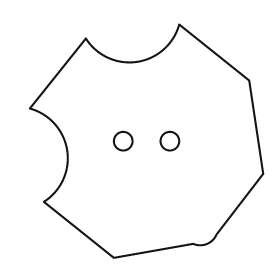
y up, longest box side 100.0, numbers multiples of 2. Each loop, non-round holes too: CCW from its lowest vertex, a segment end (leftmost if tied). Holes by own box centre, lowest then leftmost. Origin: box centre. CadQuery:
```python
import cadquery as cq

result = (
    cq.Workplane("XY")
    .moveTo(-14.0, -50.0)
    .lineTo(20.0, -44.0)
    .threePointArc((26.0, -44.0), (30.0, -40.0))
    .lineTo(50.0, -14.0)
    .lineTo(44.0, 26.0)
    .lineTo(14.0, 50.0)
    .threePointArc((-4.0, 34.0), (-26.0, 44.0))
    .lineTo(-50.0, 14.0)
    .threePointArc((-34.0, -4.0), (-44.0, -26.0))
    .close()
    .moveTo(-10.0, 0.0)
    .circle(4.0)
    .moveTo(10.0, 0.0)
    .circle(4.0)
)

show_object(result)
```